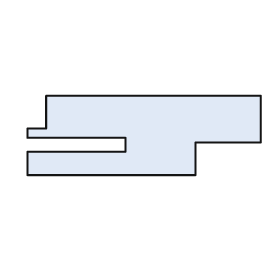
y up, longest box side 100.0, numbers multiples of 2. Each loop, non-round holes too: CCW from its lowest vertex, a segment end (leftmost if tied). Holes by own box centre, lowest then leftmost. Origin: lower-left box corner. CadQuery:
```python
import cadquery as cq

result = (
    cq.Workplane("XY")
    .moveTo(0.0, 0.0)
    .lineTo(72.0, 0.0)
    .lineTo(72.0, 14.0)
    .lineTo(100.0, 14.0)
    .lineTo(100.0, 34.0)
    .lineTo(8.0, 34.0)
    .lineTo(8.0, 20.0)
    .lineTo(0.0, 20.0)
    .lineTo(0.0, 16.0)
    .lineTo(42.0, 16.0)
    .lineTo(42.0, 10.0)
    .lineTo(0.0, 10.0)
    .close()
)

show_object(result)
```